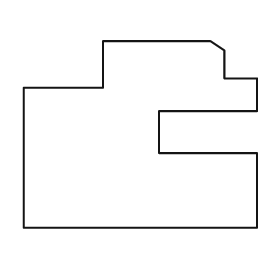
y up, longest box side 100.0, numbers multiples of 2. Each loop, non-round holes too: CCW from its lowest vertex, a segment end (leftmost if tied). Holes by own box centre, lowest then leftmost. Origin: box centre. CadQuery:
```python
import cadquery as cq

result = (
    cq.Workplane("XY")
    .moveTo(-50.0, -40.0)
    .lineTo(50.0, -40.0)
    .lineTo(50.0, -8.0)
    .lineTo(8.0, -8.0)
    .lineTo(8.0, 10.0)
    .lineTo(50.0, 10.0)
    .lineTo(50.0, 24.0)
    .lineTo(36.0, 24.0)
    .lineTo(36.0, 36.0)
    .lineTo(30.0, 40.0)
    .lineTo(-16.0, 40.0)
    .lineTo(-16.0, 20.0)
    .lineTo(-50.0, 20.0)
    .close()
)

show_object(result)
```